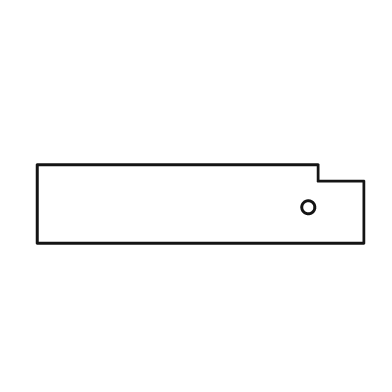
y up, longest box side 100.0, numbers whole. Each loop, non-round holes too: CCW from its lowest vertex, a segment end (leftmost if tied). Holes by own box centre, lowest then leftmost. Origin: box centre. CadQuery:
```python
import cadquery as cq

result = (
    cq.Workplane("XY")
    .moveTo(-50.0, -12.0)
    .lineTo(50.0, -12.0)
    .lineTo(50.0, 7.0)
    .lineTo(36.0, 7.0)
    .lineTo(36.0, 12.0)
    .lineTo(-50.0, 12.0)
    .close()
    .moveTo(33.0, -1.0)
    .circle(2.0)
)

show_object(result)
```